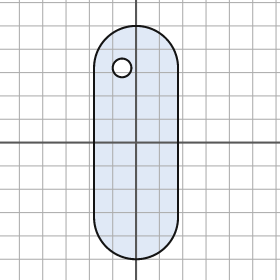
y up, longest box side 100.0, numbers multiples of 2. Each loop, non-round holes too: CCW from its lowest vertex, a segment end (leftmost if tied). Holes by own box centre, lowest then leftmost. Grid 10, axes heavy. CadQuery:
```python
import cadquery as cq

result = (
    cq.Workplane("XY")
    .moveTo(-18.0, -32.0)
    .threePointArc((0.0, -50.0), (18.0, -32.0))
    .lineTo(18.0, 32.0)
    .threePointArc((0.0, 50.0), (-18.0, 32.0))
    .close()
    .moveTo(-6.0, 32.0)
    .circle(4.0)
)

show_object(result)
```